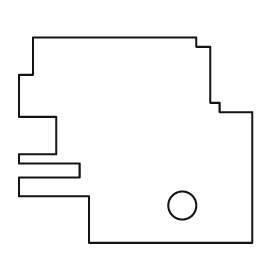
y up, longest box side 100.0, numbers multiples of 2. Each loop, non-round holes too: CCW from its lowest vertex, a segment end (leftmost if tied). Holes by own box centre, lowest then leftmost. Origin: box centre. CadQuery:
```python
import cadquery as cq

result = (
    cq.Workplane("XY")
    .moveTo(-20.0, -44.0)
    .lineTo(50.0, -44.0)
    .lineTo(50.0, 12.0)
    .lineTo(36.0, 12.0)
    .lineTo(36.0, 16.0)
    .lineTo(32.0, 16.0)
    .lineTo(32.0, 40.0)
    .lineTo(26.0, 40.0)
    .lineTo(26.0, 44.0)
    .lineTo(-44.0, 44.0)
    .lineTo(-44.0, 28.0)
    .lineTo(-50.0, 28.0)
    .lineTo(-50.0, 10.0)
    .lineTo(-34.0, 10.0)
    .lineTo(-34.0, -6.0)
    .lineTo(-50.0, -6.0)
    .lineTo(-50.0, -10.0)
    .lineTo(-24.0, -10.0)
    .lineTo(-24.0, -16.0)
    .lineTo(-50.0, -16.0)
    .lineTo(-50.0, -24.0)
    .lineTo(-20.0, -24.0)
    .close()
    .moveTo(20.0, -28.0)
    .circle(6.0)
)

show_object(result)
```